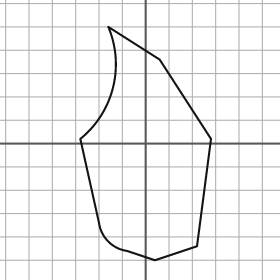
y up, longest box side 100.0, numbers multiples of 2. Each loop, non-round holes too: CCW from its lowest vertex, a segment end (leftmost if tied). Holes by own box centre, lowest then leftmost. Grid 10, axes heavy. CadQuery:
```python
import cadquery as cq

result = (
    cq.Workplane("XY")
    .moveTo(4.0, -50.0)
    .lineTo(22.0, -44.0)
    .lineTo(28.0, 2.0)
    .lineTo(6.0, 36.0)
    .lineTo(-16.0, 50.0)
    .threePointArc((-14.0, 24.0), (-28.0, 2.0))
    .lineTo(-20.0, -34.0)
    .threePointArc((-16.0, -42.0), (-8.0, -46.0))
    .close()
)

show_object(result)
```